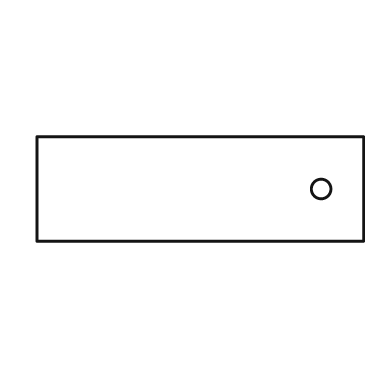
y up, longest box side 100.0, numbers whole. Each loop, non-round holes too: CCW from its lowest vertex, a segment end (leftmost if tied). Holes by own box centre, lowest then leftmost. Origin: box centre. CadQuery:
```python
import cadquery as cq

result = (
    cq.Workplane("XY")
    .moveTo(-50.0, -16.0)
    .lineTo(50.0, -16.0)
    .lineTo(50.0, 16.0)
    .lineTo(-50.0, 16.0)
    .close()
    .moveTo(37.0, 0.0)
    .circle(3.0)
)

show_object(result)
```